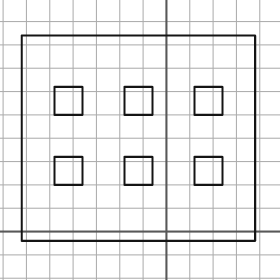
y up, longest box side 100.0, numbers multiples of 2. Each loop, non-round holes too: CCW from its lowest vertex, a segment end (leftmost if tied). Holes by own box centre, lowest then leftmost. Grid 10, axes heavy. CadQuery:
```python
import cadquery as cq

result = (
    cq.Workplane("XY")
    .moveTo(-62.0, -4.0)
    .lineTo(38.0, -4.0)
    .lineTo(38.0, 84.0)
    .lineTo(-62.0, 84.0)
    .close()
    .moveTo(-48.0, 20.0)
    .lineTo(-36.0, 20.0)
    .lineTo(-36.0, 32.0)
    .lineTo(-48.0, 32.0)
    .close()
    .moveTo(-18.0, 20.0)
    .lineTo(-6.0, 20.0)
    .lineTo(-6.0, 32.0)
    .lineTo(-18.0, 32.0)
    .close()
    .moveTo(12.0, 20.0)
    .lineTo(24.0, 20.0)
    .lineTo(24.0, 32.0)
    .lineTo(12.0, 32.0)
    .close()
    .moveTo(-48.0, 50.0)
    .lineTo(-36.0, 50.0)
    .lineTo(-36.0, 62.0)
    .lineTo(-48.0, 62.0)
    .close()
    .moveTo(-18.0, 50.0)
    .lineTo(-6.0, 50.0)
    .lineTo(-6.0, 62.0)
    .lineTo(-18.0, 62.0)
    .close()
    .moveTo(12.0, 50.0)
    .lineTo(24.0, 50.0)
    .lineTo(24.0, 62.0)
    .lineTo(12.0, 62.0)
    .close()
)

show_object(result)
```